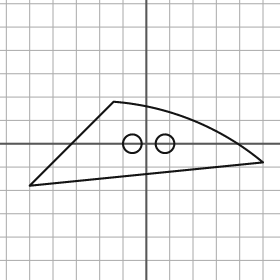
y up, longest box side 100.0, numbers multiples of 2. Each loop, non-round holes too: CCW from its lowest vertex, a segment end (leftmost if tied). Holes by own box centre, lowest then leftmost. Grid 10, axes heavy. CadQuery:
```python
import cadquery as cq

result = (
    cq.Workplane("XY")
    .moveTo(-50.0, -18.0)
    .lineTo(50.0, -8.0)
    .threePointArc((20.0, 10.0), (-14.0, 18.0))
    .close()
    .moveTo(-6.0, 0.0)
    .circle(4.0)
    .moveTo(8.0, 0.0)
    .circle(4.0)
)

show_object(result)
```